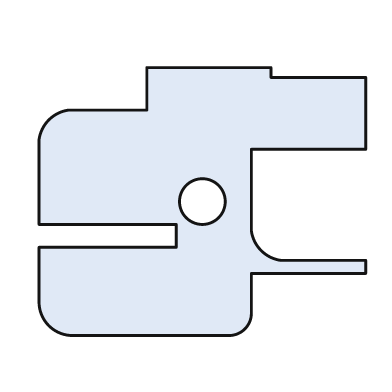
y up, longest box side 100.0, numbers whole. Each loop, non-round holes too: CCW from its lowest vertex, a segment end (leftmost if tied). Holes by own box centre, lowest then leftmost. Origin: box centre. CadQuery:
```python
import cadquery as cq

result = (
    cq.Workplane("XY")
    .moveTo(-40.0, -41.0)
    .lineTo(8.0, -41.0)
    .threePointArc((13.0, -39.0), (15.0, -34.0))
    .lineTo(15.0, -22.0)
    .lineTo(50.0, -22.0)
    .lineTo(50.0, -18.0)
    .lineTo(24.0, -18.0)
    .threePointArc((18.0, -15.0), (15.0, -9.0))
    .lineTo(15.0, 16.0)
    .lineTo(50.0, 16.0)
    .lineTo(50.0, 38.0)
    .lineTo(21.0, 38.0)
    .lineTo(21.0, 41.0)
    .lineTo(-17.0, 41.0)
    .lineTo(-17.0, 28.0)
    .lineTo(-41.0, 28.0)
    .threePointArc((-47.0, 25.0), (-50.0, 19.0))
    .lineTo(-50.0, -7.0)
    .lineTo(-8.0, -7.0)
    .lineTo(-8.0, -14.0)
    .lineTo(-50.0, -14.0)
    .lineTo(-50.0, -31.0)
    .threePointArc((-47.0, -38.0), (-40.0, -41.0))
    .close()
    .moveTo(0.0, 0.0)
    .circle(7.0)
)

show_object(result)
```